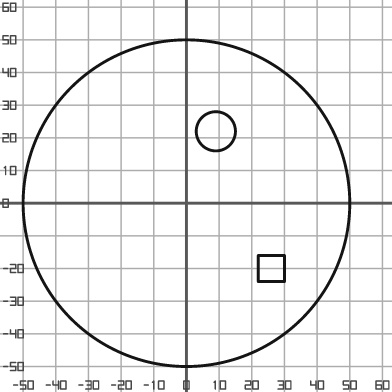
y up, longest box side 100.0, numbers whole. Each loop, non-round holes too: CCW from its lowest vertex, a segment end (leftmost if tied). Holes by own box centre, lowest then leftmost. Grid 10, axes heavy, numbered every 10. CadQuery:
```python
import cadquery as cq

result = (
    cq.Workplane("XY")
    .moveTo(0.0, 0.0)
    .circle(50.0)
    .moveTo(22.0, -24.0)
    .lineTo(30.0, -24.0)
    .lineTo(30.0, -16.0)
    .lineTo(22.0, -16.0)
    .close()
    .moveTo(9.0, 22.0)
    .circle(6.0)
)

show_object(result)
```